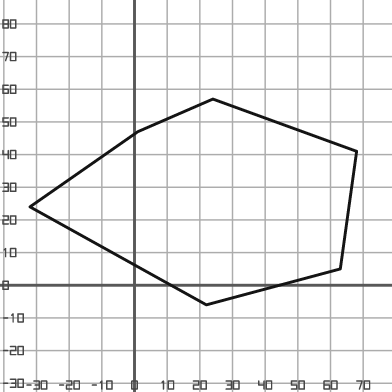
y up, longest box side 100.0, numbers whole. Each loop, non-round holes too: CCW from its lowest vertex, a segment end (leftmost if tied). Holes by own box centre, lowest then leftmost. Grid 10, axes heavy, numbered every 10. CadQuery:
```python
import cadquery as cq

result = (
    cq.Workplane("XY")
    .moveTo(22.0, -6.0)
    .lineTo(63.0, 5.0)
    .lineTo(68.0, 41.0)
    .lineTo(24.0, 57.0)
    .lineTo(1.0, 47.0)
    .lineTo(-32.0, 24.0)
    .close()
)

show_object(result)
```